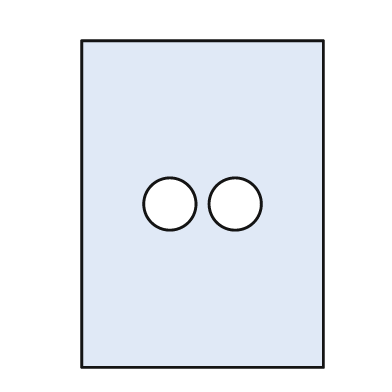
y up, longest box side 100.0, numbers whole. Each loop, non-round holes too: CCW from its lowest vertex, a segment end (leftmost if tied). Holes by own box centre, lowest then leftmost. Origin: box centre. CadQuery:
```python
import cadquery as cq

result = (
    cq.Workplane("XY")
    .moveTo(-37.0, -50.0)
    .lineTo(37.0, -50.0)
    .lineTo(37.0, 50.0)
    .lineTo(-37.0, 50.0)
    .close()
    .moveTo(-10.0, 0.0)
    .circle(8.0)
    .moveTo(10.0, 0.0)
    .circle(8.0)
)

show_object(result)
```